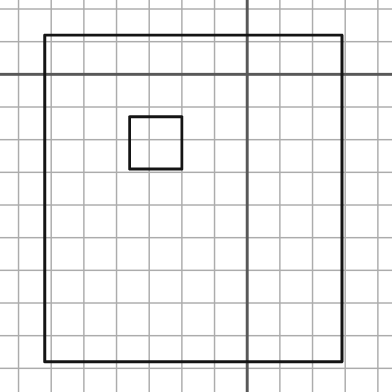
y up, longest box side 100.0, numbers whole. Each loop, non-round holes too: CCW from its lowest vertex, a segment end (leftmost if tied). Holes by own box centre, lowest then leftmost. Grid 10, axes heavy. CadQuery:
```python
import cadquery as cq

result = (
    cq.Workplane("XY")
    .moveTo(-62.0, -88.0)
    .lineTo(29.0, -88.0)
    .lineTo(29.0, 12.0)
    .lineTo(-62.0, 12.0)
    .close()
    .moveTo(-36.0, -29.0)
    .lineTo(-20.0, -29.0)
    .lineTo(-20.0, -13.0)
    .lineTo(-36.0, -13.0)
    .close()
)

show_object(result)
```